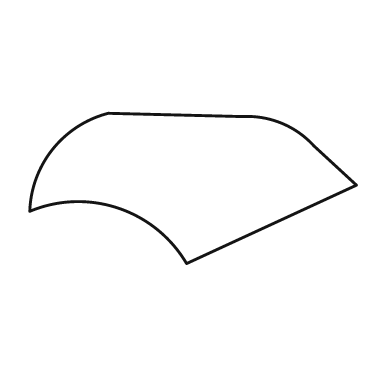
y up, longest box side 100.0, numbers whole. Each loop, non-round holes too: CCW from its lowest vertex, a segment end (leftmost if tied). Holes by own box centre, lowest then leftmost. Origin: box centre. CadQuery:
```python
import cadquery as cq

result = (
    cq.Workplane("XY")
    .moveTo(-2.0, -23.0)
    .lineTo(50.0, 1.0)
    .lineTo(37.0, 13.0)
    .threePointArc((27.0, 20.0), (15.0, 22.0))
    .lineTo(-26.0, 23.0)
    .threePointArc((-43.0, 12.0), (-50.0, -7.0))
    .threePointArc((-23.0, -6.0), (-2.0, -23.0))
    .close()
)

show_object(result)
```